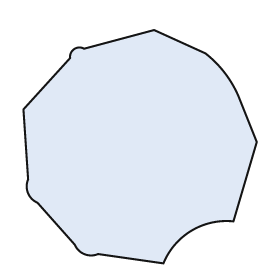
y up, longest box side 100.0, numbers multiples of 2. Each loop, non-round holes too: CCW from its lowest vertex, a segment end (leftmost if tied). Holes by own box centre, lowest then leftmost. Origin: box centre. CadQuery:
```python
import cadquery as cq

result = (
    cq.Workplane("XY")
    .moveTo(10.0, -50.0)
    .threePointArc((22.0, -36.0), (40.0, -32.0))
    .lineTo(50.0, 2.0)
    .lineTo(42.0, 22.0)
    .threePointArc((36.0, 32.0), (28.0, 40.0))
    .lineTo(6.0, 50.0)
    .lineTo(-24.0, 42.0)
    .threePointArc((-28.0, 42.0), (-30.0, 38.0))
    .lineTo(-50.0, 16.0)
    .lineTo(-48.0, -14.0)
    .threePointArc((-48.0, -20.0), (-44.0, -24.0))
    .lineTo(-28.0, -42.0)
    .threePointArc((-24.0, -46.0), (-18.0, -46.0))
    .close()
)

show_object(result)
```